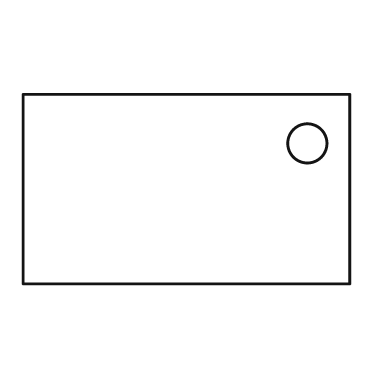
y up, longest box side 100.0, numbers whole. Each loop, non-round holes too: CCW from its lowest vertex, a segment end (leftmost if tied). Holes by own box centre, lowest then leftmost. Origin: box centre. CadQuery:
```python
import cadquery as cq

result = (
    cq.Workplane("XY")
    .moveTo(-50.0, -29.0)
    .lineTo(50.0, -29.0)
    .lineTo(50.0, 29.0)
    .lineTo(-50.0, 29.0)
    .close()
    .moveTo(37.0, 14.0)
    .circle(6.0)
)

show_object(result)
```